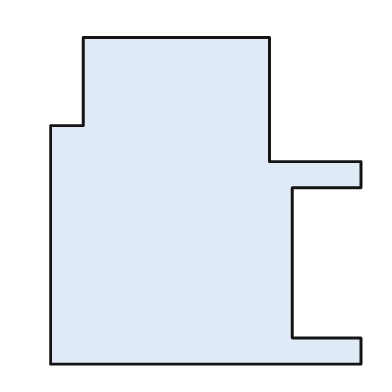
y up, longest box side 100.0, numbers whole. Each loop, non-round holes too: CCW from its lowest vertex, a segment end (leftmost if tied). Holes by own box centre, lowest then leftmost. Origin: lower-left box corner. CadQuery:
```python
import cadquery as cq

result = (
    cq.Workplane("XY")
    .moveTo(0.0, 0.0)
    .lineTo(95.0, 0.0)
    .lineTo(95.0, 8.0)
    .lineTo(74.0, 8.0)
    .lineTo(74.0, 54.0)
    .lineTo(95.0, 54.0)
    .lineTo(95.0, 62.0)
    .lineTo(67.0, 62.0)
    .lineTo(67.0, 100.0)
    .lineTo(10.0, 100.0)
    .lineTo(10.0, 73.0)
    .lineTo(0.0, 73.0)
    .close()
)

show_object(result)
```